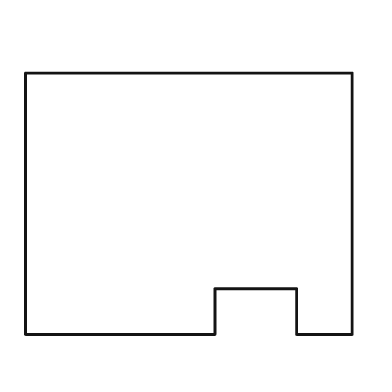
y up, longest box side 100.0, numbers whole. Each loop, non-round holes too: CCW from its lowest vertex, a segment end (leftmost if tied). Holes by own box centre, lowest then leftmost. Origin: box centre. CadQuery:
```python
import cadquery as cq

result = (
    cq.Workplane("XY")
    .moveTo(-50.0, -40.0)
    .lineTo(8.0, -40.0)
    .lineTo(8.0, -26.0)
    .lineTo(33.0, -26.0)
    .lineTo(33.0, -40.0)
    .lineTo(50.0, -40.0)
    .lineTo(50.0, 40.0)
    .lineTo(-50.0, 40.0)
    .close()
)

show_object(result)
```